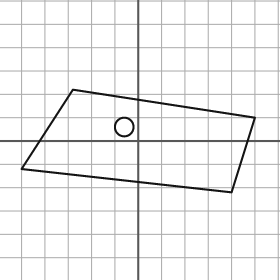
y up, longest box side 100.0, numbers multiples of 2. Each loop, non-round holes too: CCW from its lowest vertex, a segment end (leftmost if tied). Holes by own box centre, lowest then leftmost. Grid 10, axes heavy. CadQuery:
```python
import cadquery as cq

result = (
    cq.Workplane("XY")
    .moveTo(40.0, -22.0)
    .lineTo(50.0, 10.0)
    .lineTo(-28.0, 22.0)
    .lineTo(-50.0, -12.0)
    .close()
    .moveTo(-6.0, 6.0)
    .circle(4.0)
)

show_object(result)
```